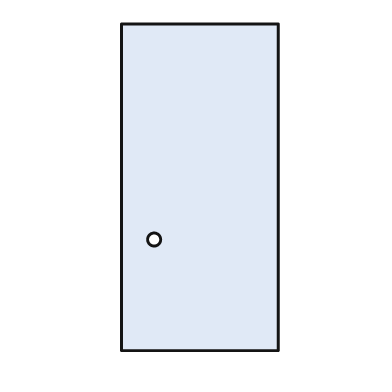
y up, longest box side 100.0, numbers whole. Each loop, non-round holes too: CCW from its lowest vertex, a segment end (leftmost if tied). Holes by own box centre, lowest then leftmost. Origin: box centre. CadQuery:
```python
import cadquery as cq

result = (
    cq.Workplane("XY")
    .moveTo(-24.0, -50.0)
    .lineTo(24.0, -50.0)
    .lineTo(24.0, 50.0)
    .lineTo(-24.0, 50.0)
    .close()
    .moveTo(-14.0, -16.0)
    .circle(2.0)
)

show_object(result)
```